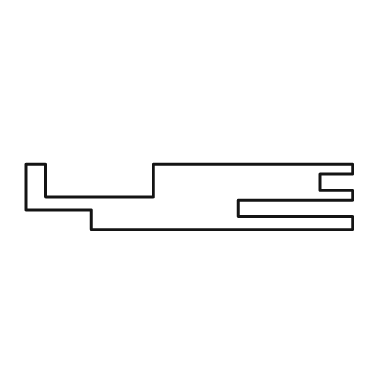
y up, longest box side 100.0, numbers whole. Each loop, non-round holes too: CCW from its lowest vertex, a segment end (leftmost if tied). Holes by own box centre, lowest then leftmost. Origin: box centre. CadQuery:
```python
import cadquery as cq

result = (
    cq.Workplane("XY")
    .moveTo(-30.0, -10.0)
    .lineTo(50.0, -10.0)
    .lineTo(50.0, -6.0)
    .lineTo(15.0, -6.0)
    .lineTo(15.0, -1.0)
    .lineTo(50.0, -1.0)
    .lineTo(50.0, 2.0)
    .lineTo(40.0, 2.0)
    .lineTo(40.0, 7.0)
    .lineTo(50.0, 7.0)
    .lineTo(50.0, 10.0)
    .lineTo(-11.0, 10.0)
    .lineTo(-11.0, 0.0)
    .lineTo(-44.0, 0.0)
    .lineTo(-44.0, 10.0)
    .lineTo(-50.0, 10.0)
    .lineTo(-50.0, -4.0)
    .lineTo(-30.0, -4.0)
    .close()
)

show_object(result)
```